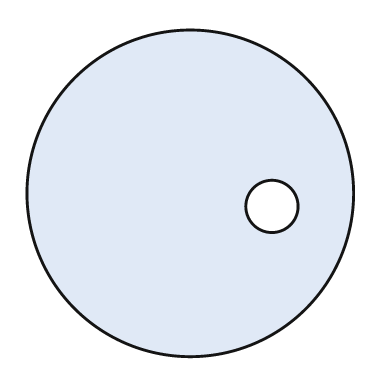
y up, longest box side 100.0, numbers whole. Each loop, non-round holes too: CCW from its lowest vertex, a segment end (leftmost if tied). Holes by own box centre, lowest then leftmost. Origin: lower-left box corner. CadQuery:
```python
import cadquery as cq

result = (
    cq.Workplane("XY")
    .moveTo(50.0, 50.0)
    .circle(50.0)
    .moveTo(75.0, 46.0)
    .circle(8.0)
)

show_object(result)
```